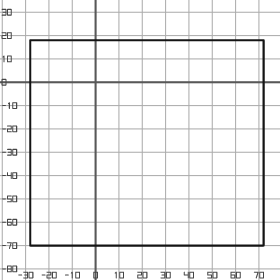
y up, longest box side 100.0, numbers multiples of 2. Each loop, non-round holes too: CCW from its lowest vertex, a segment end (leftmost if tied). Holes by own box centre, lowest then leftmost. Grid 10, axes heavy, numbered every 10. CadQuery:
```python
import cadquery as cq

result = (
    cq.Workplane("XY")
    .moveTo(-28.0, -70.0)
    .lineTo(72.0, -70.0)
    .lineTo(72.0, 18.0)
    .lineTo(-28.0, 18.0)
    .close()
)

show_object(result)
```